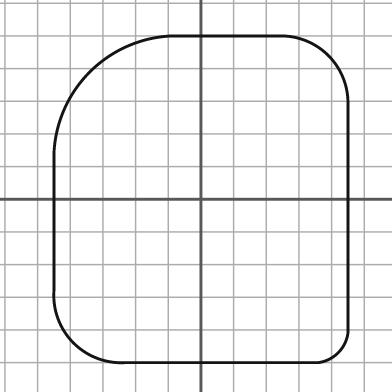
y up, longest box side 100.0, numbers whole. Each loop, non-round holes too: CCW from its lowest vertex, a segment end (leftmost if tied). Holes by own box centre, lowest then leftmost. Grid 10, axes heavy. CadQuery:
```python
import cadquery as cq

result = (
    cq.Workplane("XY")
    .moveTo(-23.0, -50.0)
    .lineTo(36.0, -50.0)
    .threePointArc((42.0, -47.0), (45.0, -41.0))
    .lineTo(45.0, 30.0)
    .threePointArc((39.0, 44.0), (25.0, 50.0))
    .lineTo(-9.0, 50.0)
    .threePointArc((-34.0, 39.0), (-45.0, 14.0))
    .lineTo(-45.0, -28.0)
    .threePointArc((-39.0, -44.0), (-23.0, -50.0))
    .close()
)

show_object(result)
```